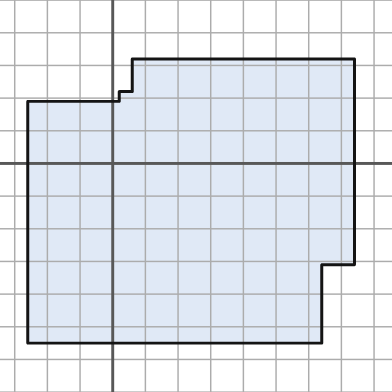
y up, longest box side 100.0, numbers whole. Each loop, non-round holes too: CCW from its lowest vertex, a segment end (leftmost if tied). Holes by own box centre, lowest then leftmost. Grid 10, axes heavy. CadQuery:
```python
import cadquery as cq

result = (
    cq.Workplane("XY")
    .moveTo(-26.0, -55.0)
    .lineTo(64.0, -55.0)
    .lineTo(64.0, -31.0)
    .lineTo(74.0, -31.0)
    .lineTo(74.0, 32.0)
    .lineTo(6.0, 32.0)
    .lineTo(6.0, 22.0)
    .lineTo(2.0, 22.0)
    .lineTo(2.0, 19.0)
    .lineTo(-26.0, 19.0)
    .close()
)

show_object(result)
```